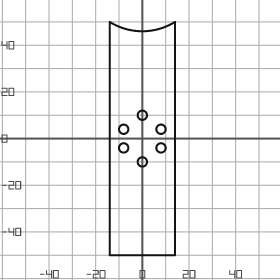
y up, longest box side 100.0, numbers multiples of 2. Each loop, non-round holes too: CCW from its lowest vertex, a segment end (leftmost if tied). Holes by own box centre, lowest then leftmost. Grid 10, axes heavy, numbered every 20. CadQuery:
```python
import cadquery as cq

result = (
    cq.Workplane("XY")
    .moveTo(-14.0, -50.0)
    .lineTo(14.0, -50.0)
    .lineTo(14.0, 50.0)
    .threePointArc((0.0, 46.0), (-14.0, 50.0))
    .close()
    .moveTo(0.0, -10.0)
    .circle(2.0)
    .moveTo(-8.0, -4.0)
    .circle(2.0)
    .moveTo(8.0, -4.0)
    .circle(2.0)
    .moveTo(-8.0, 4.0)
    .circle(2.0)
    .moveTo(8.0, 4.0)
    .circle(2.0)
    .moveTo(0.0, 10.0)
    .circle(2.0)
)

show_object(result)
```